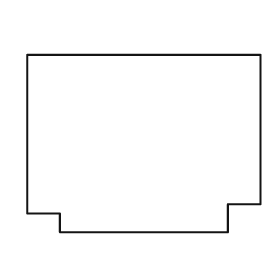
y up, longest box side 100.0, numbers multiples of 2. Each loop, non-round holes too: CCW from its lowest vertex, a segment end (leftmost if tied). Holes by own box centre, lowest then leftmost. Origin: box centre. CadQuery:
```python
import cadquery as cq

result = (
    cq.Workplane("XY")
    .moveTo(-36.0, -38.0)
    .lineTo(36.0, -38.0)
    .lineTo(36.0, -26.0)
    .lineTo(50.0, -26.0)
    .lineTo(50.0, 38.0)
    .lineTo(-50.0, 38.0)
    .lineTo(-50.0, -30.0)
    .lineTo(-36.0, -30.0)
    .close()
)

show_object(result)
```